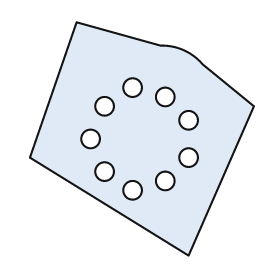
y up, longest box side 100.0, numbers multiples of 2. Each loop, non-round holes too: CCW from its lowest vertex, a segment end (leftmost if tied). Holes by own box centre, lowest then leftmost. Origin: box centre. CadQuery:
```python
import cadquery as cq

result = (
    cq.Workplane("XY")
    .moveTo(20.0, -50.0)
    .lineTo(48.0, 14.0)
    .lineTo(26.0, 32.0)
    .threePointArc((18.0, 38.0), (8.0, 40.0))
    .lineTo(-28.0, 50.0)
    .lineTo(-48.0, -8.0)
    .close()
    .moveTo(-4.0, -22.0)
    .circle(4.0)
    .moveTo(10.0, -18.0)
    .circle(4.0)
    .moveTo(-16.0, -14.0)
    .circle(4.0)
    .moveTo(20.0, -8.0)
    .circle(4.0)
    .moveTo(-22.0, 0.0)
    .circle(4.0)
    .moveTo(20.0, 8.0)
    .circle(4.0)
    .moveTo(-16.0, 14.0)
    .circle(4.0)
    .moveTo(10.0, 18.0)
    .circle(4.0)
    .moveTo(-4.0, 22.0)
    .circle(4.0)
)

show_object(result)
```